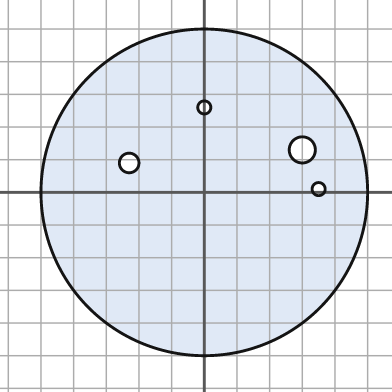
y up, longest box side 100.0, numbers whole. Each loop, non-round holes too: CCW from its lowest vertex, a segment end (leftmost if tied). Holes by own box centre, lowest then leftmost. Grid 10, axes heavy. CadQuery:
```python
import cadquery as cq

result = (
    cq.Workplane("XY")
    .moveTo(0.0, 0.0)
    .circle(50.0)
    .moveTo(35.0, 1.0)
    .circle(2.0)
    .moveTo(-23.0, 9.0)
    .circle(3.0)
    .moveTo(30.0, 13.0)
    .circle(4.0)
    .moveTo(0.0, 26.0)
    .circle(2.0)
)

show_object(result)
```